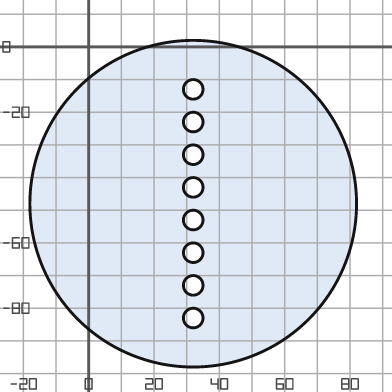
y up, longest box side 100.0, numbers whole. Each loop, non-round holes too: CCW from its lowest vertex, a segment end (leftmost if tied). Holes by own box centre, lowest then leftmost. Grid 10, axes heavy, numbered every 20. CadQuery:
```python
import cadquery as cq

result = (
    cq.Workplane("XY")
    .moveTo(32.0, -48.0)
    .circle(50.0)
    .moveTo(32.0, -83.0)
    .circle(3.0)
    .moveTo(32.0, -73.0)
    .circle(3.0)
    .moveTo(32.0, -63.0)
    .circle(3.0)
    .moveTo(32.0, -53.0)
    .circle(3.0)
    .moveTo(32.0, -43.0)
    .circle(3.0)
    .moveTo(32.0, -33.0)
    .circle(3.0)
    .moveTo(32.0, -23.0)
    .circle(3.0)
    .moveTo(32.0, -13.0)
    .circle(3.0)
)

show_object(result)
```